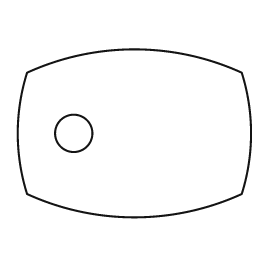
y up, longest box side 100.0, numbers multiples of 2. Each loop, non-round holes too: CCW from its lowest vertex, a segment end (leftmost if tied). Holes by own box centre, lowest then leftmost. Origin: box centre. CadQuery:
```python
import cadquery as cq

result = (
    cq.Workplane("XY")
    .moveTo(-46.0, -26.0)
    .threePointArc((0.0, -36.0), (46.0, -26.0))
    .threePointArc((50.0, 0.0), (46.0, 26.0))
    .threePointArc((0.0, 36.0), (-46.0, 26.0))
    .threePointArc((-50.0, 0.0), (-46.0, -26.0))
    .close()
    .moveTo(-26.0, 0.0)
    .circle(8.0)
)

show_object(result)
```